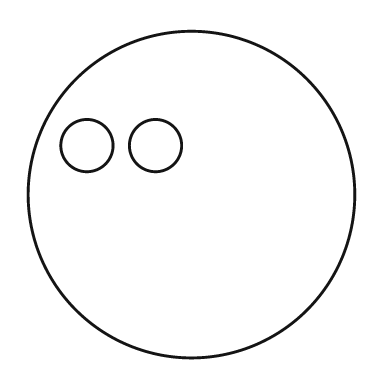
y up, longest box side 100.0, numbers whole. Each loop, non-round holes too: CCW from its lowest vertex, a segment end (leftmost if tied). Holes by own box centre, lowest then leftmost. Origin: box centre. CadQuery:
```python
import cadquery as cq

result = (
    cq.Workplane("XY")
    .moveTo(0.0, 0.0)
    .circle(50.0)
    .moveTo(-32.0, 15.0)
    .circle(8.0)
    .moveTo(-11.0, 15.0)
    .circle(8.0)
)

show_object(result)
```